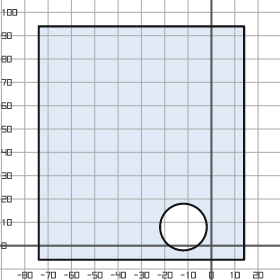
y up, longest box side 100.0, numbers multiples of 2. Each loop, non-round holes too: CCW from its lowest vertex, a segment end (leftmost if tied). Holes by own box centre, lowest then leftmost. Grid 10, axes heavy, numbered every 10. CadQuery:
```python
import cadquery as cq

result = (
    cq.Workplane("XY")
    .moveTo(-74.0, -6.0)
    .lineTo(14.0, -6.0)
    .lineTo(14.0, 94.0)
    .lineTo(-74.0, 94.0)
    .close()
    .moveTo(-12.0, 8.0)
    .circle(10.0)
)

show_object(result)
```